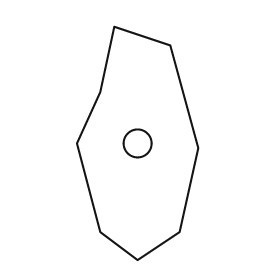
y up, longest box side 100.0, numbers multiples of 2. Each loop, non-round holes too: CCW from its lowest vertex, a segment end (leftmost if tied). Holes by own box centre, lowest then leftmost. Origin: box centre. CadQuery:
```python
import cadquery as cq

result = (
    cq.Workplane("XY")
    .moveTo(0.0, -50.0)
    .lineTo(18.0, -38.0)
    .lineTo(26.0, -2.0)
    .lineTo(14.0, 42.0)
    .lineTo(-10.0, 50.0)
    .lineTo(-16.0, 22.0)
    .lineTo(-26.0, 0.0)
    .lineTo(-16.0, -38.0)
    .close()
    .moveTo(0.0, 0.0)
    .circle(6.0)
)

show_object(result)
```